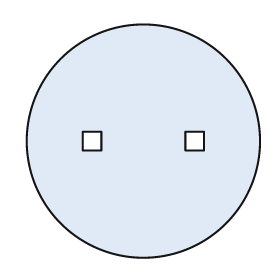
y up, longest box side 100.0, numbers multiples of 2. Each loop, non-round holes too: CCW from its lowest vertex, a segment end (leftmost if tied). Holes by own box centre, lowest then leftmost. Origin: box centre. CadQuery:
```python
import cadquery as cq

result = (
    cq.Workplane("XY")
    .moveTo(0.0, 0.0)
    .circle(50.0)
    .moveTo(-26.0, -4.0)
    .lineTo(-18.0, -4.0)
    .lineTo(-18.0, 4.0)
    .lineTo(-26.0, 4.0)
    .close()
    .moveTo(18.0, -4.0)
    .lineTo(26.0, -4.0)
    .lineTo(26.0, 4.0)
    .lineTo(18.0, 4.0)
    .close()
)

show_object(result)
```